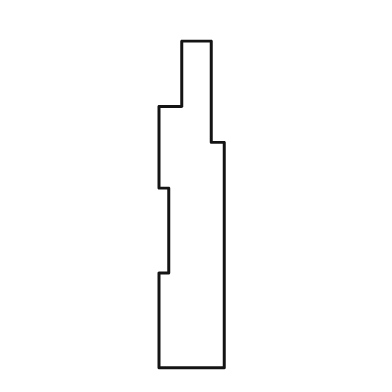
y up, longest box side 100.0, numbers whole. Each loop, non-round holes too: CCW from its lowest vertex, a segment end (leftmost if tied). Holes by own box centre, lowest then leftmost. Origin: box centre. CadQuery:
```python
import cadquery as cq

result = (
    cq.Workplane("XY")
    .moveTo(-10.0, -50.0)
    .lineTo(10.0, -50.0)
    .lineTo(10.0, 19.0)
    .lineTo(6.0, 19.0)
    .lineTo(6.0, 50.0)
    .lineTo(-3.0, 50.0)
    .lineTo(-3.0, 30.0)
    .lineTo(-10.0, 30.0)
    .lineTo(-10.0, 5.0)
    .lineTo(-7.0, 5.0)
    .lineTo(-7.0, -21.0)
    .lineTo(-10.0, -21.0)
    .close()
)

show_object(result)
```